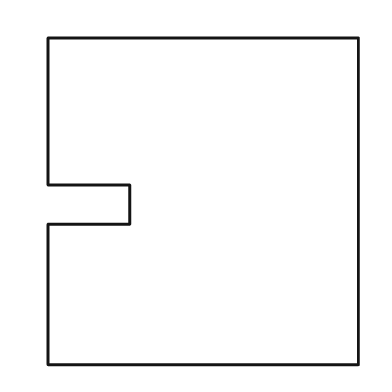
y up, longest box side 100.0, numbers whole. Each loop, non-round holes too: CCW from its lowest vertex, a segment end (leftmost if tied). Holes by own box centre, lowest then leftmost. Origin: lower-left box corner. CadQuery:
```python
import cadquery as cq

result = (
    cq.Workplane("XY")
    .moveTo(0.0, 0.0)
    .lineTo(95.0, 0.0)
    .lineTo(95.0, 100.0)
    .lineTo(0.0, 100.0)
    .lineTo(0.0, 55.0)
    .lineTo(25.0, 55.0)
    .lineTo(25.0, 43.0)
    .lineTo(0.0, 43.0)
    .close()
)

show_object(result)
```